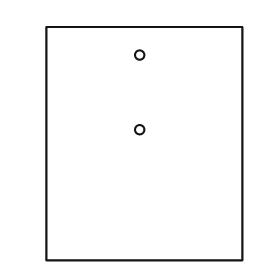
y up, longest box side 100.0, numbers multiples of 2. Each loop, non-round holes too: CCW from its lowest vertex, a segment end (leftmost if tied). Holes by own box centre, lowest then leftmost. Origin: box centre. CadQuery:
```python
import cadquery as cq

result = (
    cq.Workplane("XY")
    .moveTo(-42.0, -50.0)
    .lineTo(42.0, -50.0)
    .lineTo(42.0, 50.0)
    .lineTo(-42.0, 50.0)
    .close()
    .moveTo(-2.0, 6.0)
    .circle(2.0)
    .moveTo(-2.0, 38.0)
    .circle(2.0)
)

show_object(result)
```